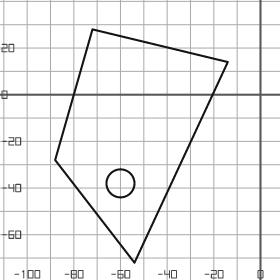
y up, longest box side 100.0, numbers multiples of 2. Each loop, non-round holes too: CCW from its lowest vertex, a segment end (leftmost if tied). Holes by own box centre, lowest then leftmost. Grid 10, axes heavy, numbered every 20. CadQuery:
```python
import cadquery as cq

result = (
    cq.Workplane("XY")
    .moveTo(-54.0, -72.0)
    .lineTo(-14.0, 14.0)
    .lineTo(-72.0, 28.0)
    .lineTo(-88.0, -28.0)
    .close()
    .moveTo(-60.0, -38.0)
    .circle(6.0)
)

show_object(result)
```